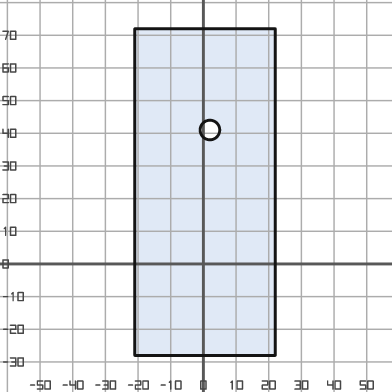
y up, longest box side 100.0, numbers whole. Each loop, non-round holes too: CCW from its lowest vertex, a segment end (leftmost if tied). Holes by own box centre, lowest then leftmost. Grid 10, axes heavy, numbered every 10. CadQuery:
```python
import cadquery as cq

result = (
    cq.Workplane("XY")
    .moveTo(-21.0, -28.0)
    .lineTo(22.0, -28.0)
    .lineTo(22.0, 72.0)
    .lineTo(-21.0, 72.0)
    .close()
    .moveTo(2.0, 41.0)
    .circle(3.0)
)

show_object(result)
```